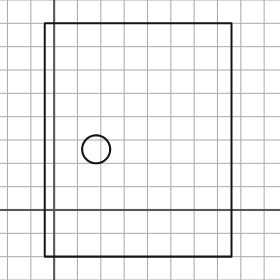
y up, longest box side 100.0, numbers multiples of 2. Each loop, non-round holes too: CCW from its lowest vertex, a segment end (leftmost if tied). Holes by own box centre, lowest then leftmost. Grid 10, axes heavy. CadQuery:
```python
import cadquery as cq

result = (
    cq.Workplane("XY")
    .moveTo(-4.0, -20.0)
    .lineTo(76.0, -20.0)
    .lineTo(76.0, 80.0)
    .lineTo(-4.0, 80.0)
    .close()
    .moveTo(18.0, 26.0)
    .circle(6.0)
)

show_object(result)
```